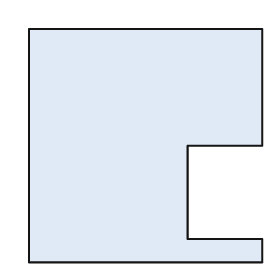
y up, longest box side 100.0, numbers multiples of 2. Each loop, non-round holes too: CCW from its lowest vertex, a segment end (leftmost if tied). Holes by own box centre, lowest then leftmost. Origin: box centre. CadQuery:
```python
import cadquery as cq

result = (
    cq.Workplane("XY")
    .moveTo(-50.0, -50.0)
    .lineTo(50.0, -50.0)
    .lineTo(50.0, -40.0)
    .lineTo(18.0, -40.0)
    .lineTo(18.0, 0.0)
    .lineTo(50.0, 0.0)
    .lineTo(50.0, 50.0)
    .lineTo(-50.0, 50.0)
    .close()
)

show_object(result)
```